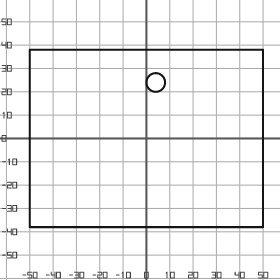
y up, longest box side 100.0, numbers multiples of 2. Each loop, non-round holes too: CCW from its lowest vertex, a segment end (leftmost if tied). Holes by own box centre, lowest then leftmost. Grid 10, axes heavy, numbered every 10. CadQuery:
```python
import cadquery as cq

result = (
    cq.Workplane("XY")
    .moveTo(-50.0, -38.0)
    .lineTo(50.0, -38.0)
    .lineTo(50.0, 38.0)
    .lineTo(-50.0, 38.0)
    .close()
    .moveTo(4.0, 24.0)
    .circle(4.0)
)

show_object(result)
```